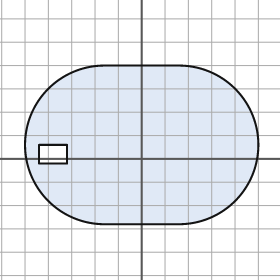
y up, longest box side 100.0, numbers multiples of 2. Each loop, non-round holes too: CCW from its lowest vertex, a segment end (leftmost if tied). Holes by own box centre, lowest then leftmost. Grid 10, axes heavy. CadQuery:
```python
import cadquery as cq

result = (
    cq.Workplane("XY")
    .moveTo(-16.0, -28.0)
    .lineTo(16.0, -28.0)
    .threePointArc((50.0, 6.0), (16.0, 40.0))
    .lineTo(-16.0, 40.0)
    .threePointArc((-50.0, 6.0), (-16.0, -28.0))
    .close()
    .moveTo(-44.0, -2.0)
    .lineTo(-32.0, -2.0)
    .lineTo(-32.0, 6.0)
    .lineTo(-44.0, 6.0)
    .close()
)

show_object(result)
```